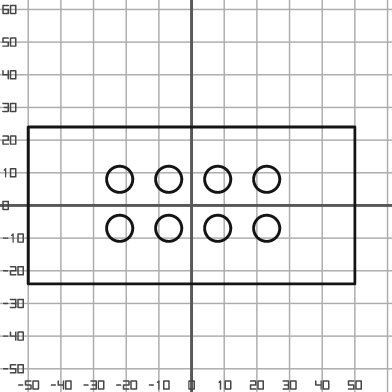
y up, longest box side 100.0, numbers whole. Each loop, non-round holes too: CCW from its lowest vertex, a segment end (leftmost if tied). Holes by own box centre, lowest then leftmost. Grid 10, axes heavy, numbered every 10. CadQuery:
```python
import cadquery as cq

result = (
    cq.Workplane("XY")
    .moveTo(-50.0, -24.0)
    .lineTo(50.0, -24.0)
    .lineTo(50.0, 24.0)
    .lineTo(-50.0, 24.0)
    .close()
    .moveTo(-22.0, -7.0)
    .circle(4.0)
    .moveTo(-7.0, -7.0)
    .circle(4.0)
    .moveTo(8.0, -7.0)
    .circle(4.0)
    .moveTo(23.0, -7.0)
    .circle(4.0)
    .moveTo(-22.0, 8.0)
    .circle(4.0)
    .moveTo(-7.0, 8.0)
    .circle(4.0)
    .moveTo(8.0, 8.0)
    .circle(4.0)
    .moveTo(23.0, 8.0)
    .circle(4.0)
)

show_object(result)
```